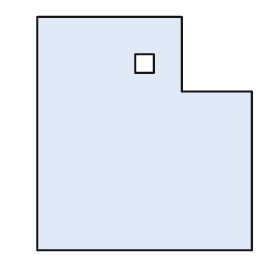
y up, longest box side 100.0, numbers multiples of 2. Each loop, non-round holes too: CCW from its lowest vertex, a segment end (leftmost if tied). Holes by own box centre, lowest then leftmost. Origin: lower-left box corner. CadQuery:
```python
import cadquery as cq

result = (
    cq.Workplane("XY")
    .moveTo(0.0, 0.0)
    .lineTo(92.0, 0.0)
    .lineTo(92.0, 68.0)
    .lineTo(62.0, 68.0)
    .lineTo(62.0, 100.0)
    .lineTo(0.0, 100.0)
    .close()
    .moveTo(42.0, 76.0)
    .lineTo(50.0, 76.0)
    .lineTo(50.0, 84.0)
    .lineTo(42.0, 84.0)
    .close()
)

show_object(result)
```